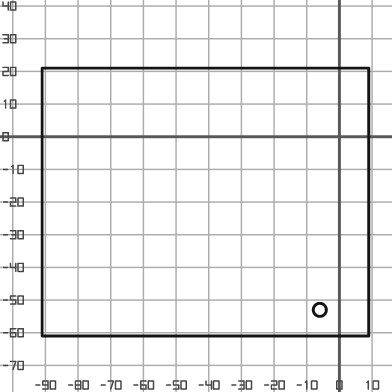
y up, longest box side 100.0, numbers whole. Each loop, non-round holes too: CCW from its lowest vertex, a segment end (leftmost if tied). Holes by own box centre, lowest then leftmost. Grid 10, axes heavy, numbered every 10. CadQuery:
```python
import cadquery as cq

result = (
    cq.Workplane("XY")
    .moveTo(-91.0, -61.0)
    .lineTo(9.0, -61.0)
    .lineTo(9.0, 21.0)
    .lineTo(-91.0, 21.0)
    .close()
    .moveTo(-6.0, -53.0)
    .circle(2.0)
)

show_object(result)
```